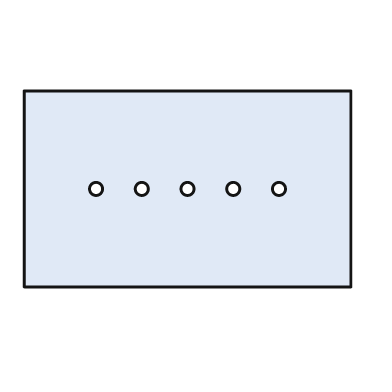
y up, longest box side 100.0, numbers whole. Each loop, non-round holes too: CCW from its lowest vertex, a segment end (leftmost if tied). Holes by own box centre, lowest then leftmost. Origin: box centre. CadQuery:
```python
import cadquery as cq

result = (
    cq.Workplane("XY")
    .moveTo(-50.0, -30.0)
    .lineTo(50.0, -30.0)
    .lineTo(50.0, 30.0)
    .lineTo(-50.0, 30.0)
    .close()
    .moveTo(-28.0, 0.0)
    .circle(2.0)
    .moveTo(-14.0, 0.0)
    .circle(2.0)
    .moveTo(0.0, 0.0)
    .circle(2.0)
    .moveTo(14.0, 0.0)
    .circle(2.0)
    .moveTo(28.0, 0.0)
    .circle(2.0)
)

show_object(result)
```